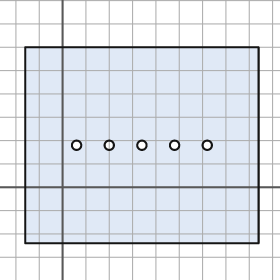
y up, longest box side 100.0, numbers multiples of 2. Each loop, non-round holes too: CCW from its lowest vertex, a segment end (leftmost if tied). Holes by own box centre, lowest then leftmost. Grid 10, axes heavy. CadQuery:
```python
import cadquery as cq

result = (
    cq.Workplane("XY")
    .moveTo(-16.0, -24.0)
    .lineTo(84.0, -24.0)
    .lineTo(84.0, 60.0)
    .lineTo(-16.0, 60.0)
    .close()
    .moveTo(6.0, 18.0)
    .circle(2.0)
    .moveTo(20.0, 18.0)
    .circle(2.0)
    .moveTo(34.0, 18.0)
    .circle(2.0)
    .moveTo(48.0, 18.0)
    .circle(2.0)
    .moveTo(62.0, 18.0)
    .circle(2.0)
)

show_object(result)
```